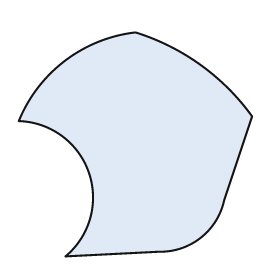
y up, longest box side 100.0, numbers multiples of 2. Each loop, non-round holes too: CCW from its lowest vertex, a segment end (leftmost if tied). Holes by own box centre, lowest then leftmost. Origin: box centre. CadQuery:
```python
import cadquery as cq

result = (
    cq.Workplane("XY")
    .moveTo(-30.0, -48.0)
    .lineTo(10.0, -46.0)
    .threePointArc((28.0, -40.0), (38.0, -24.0))
    .lineTo(50.0, 12.0)
    .threePointArc((28.0, 34.0), (0.0, 48.0))
    .threePointArc((-30.0, 36.0), (-50.0, 10.0))
    .threePointArc((-20.0, -12.0), (-30.0, -48.0))
    .close()
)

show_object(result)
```